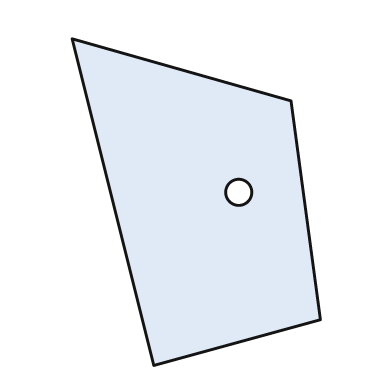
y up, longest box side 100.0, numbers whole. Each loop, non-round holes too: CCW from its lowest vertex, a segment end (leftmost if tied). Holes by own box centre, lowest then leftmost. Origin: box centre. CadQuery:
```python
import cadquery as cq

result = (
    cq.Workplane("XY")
    .moveTo(-13.0, -50.0)
    .lineTo(38.0, -36.0)
    .lineTo(29.0, 31.0)
    .lineTo(-38.0, 50.0)
    .close()
    .moveTo(13.0, 3.0)
    .circle(4.0)
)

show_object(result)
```